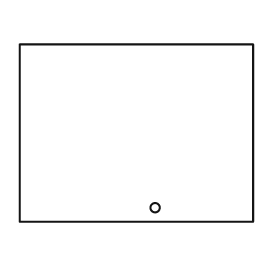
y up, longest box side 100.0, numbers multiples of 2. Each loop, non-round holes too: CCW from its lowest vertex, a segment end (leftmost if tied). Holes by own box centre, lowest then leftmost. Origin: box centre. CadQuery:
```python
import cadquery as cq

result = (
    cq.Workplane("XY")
    .moveTo(-50.0, -38.0)
    .lineTo(50.0, -38.0)
    .lineTo(50.0, 38.0)
    .lineTo(-50.0, 38.0)
    .close()
    .moveTo(8.0, -32.0)
    .circle(2.0)
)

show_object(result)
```